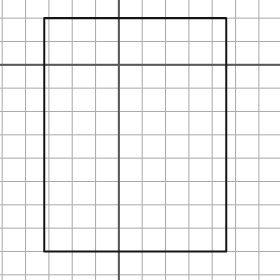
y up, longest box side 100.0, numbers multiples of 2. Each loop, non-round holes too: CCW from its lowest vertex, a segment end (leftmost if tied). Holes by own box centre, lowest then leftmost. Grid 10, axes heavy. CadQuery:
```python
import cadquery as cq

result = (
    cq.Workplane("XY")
    .moveTo(-32.0, -80.0)
    .lineTo(46.0, -80.0)
    .lineTo(46.0, 20.0)
    .lineTo(-32.0, 20.0)
    .close()
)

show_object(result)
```